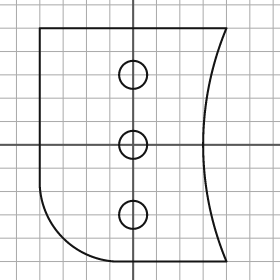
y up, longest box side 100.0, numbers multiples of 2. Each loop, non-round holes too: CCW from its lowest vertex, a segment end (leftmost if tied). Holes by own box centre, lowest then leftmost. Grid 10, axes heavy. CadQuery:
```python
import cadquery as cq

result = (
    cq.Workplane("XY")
    .moveTo(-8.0, -50.0)
    .lineTo(40.0, -50.0)
    .threePointArc((30.0, 0.0), (40.0, 50.0))
    .lineTo(-40.0, 50.0)
    .lineTo(-40.0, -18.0)
    .threePointArc((-30.0, -40.0), (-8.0, -50.0))
    .close()
    .moveTo(0.0, -30.0)
    .circle(6.0)
    .moveTo(0.0, 0.0)
    .circle(6.0)
    .moveTo(0.0, 30.0)
    .circle(6.0)
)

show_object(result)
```